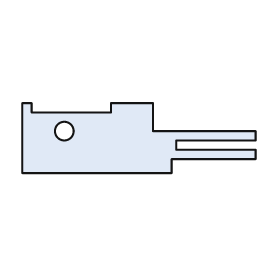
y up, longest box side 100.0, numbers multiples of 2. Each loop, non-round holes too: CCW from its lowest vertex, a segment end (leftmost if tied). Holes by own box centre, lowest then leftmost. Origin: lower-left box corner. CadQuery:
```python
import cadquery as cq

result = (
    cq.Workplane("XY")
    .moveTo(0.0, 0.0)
    .lineTo(64.0, 0.0)
    .lineTo(64.0, 6.0)
    .lineTo(100.0, 6.0)
    .lineTo(100.0, 10.0)
    .lineTo(66.0, 10.0)
    .lineTo(66.0, 14.0)
    .lineTo(100.0, 14.0)
    .lineTo(100.0, 18.0)
    .lineTo(56.0, 18.0)
    .lineTo(56.0, 30.0)
    .lineTo(38.0, 30.0)
    .lineTo(38.0, 26.0)
    .lineTo(4.0, 26.0)
    .lineTo(4.0, 30.0)
    .lineTo(0.0, 30.0)
    .close()
    .moveTo(18.0, 18.0)
    .circle(4.0)
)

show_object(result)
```